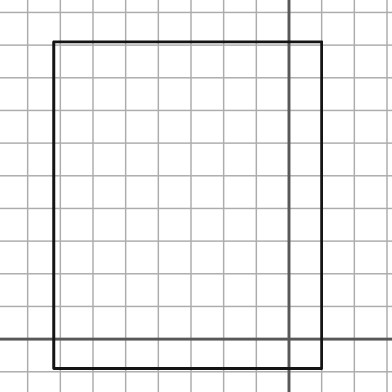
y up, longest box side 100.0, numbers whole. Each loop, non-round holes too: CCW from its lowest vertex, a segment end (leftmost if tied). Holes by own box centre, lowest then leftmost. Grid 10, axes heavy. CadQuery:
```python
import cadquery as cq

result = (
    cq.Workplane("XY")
    .moveTo(-72.0, -9.0)
    .lineTo(10.0, -9.0)
    .lineTo(10.0, 91.0)
    .lineTo(-72.0, 91.0)
    .close()
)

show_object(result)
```